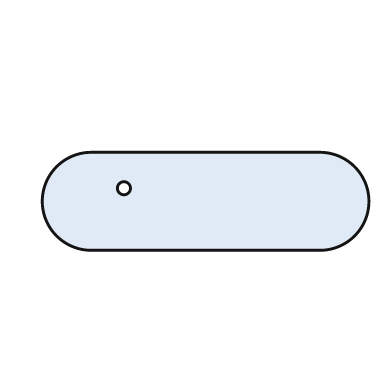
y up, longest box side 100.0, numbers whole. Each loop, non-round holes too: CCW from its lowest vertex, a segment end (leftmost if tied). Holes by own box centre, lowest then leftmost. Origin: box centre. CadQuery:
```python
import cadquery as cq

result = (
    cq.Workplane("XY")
    .moveTo(-35.0, -15.0)
    .lineTo(35.0, -15.0)
    .threePointArc((50.0, 0.0), (35.0, 15.0))
    .lineTo(-35.0, 15.0)
    .threePointArc((-50.0, 0.0), (-35.0, -15.0))
    .close()
    .moveTo(-25.0, 4.0)
    .circle(2.0)
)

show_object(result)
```